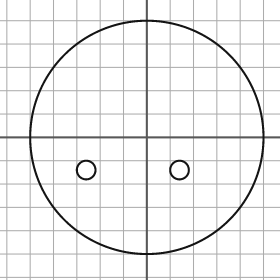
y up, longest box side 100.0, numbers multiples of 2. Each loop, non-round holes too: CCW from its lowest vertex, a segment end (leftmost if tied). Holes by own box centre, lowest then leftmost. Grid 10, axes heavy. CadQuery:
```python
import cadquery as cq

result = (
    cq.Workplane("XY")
    .moveTo(0.0, 0.0)
    .circle(50.0)
    .moveTo(-26.0, -14.0)
    .circle(4.0)
    .moveTo(14.0, -14.0)
    .circle(4.0)
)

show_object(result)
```